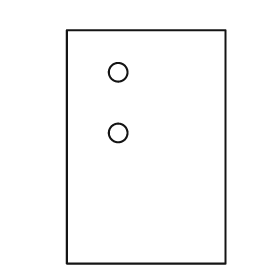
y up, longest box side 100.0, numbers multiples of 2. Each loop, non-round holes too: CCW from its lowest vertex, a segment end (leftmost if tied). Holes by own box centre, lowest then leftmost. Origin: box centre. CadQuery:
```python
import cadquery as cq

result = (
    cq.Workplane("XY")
    .moveTo(-34.0, -50.0)
    .lineTo(34.0, -50.0)
    .lineTo(34.0, 50.0)
    .lineTo(-34.0, 50.0)
    .close()
    .moveTo(-12.0, 6.0)
    .circle(4.0)
    .moveTo(-12.0, 32.0)
    .circle(4.0)
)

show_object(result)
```